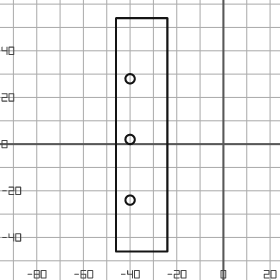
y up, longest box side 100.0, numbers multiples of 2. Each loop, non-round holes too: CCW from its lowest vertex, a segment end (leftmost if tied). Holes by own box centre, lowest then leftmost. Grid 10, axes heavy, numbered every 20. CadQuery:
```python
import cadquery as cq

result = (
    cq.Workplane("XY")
    .moveTo(-46.0, -46.0)
    .lineTo(-24.0, -46.0)
    .lineTo(-24.0, 54.0)
    .lineTo(-46.0, 54.0)
    .close()
    .moveTo(-40.0, -24.0)
    .circle(2.0)
    .moveTo(-40.0, 2.0)
    .circle(2.0)
    .moveTo(-40.0, 28.0)
    .circle(2.0)
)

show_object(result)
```